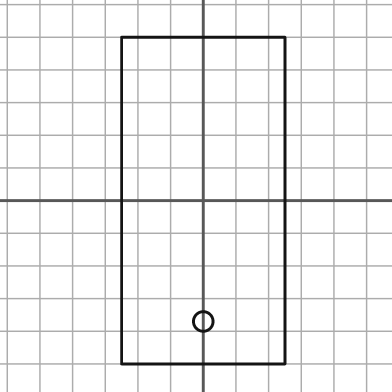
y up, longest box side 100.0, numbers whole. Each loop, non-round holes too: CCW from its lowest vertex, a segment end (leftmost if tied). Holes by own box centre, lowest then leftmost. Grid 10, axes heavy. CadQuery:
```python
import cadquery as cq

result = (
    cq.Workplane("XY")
    .moveTo(-25.0, -50.0)
    .lineTo(25.0, -50.0)
    .lineTo(25.0, 50.0)
    .lineTo(-25.0, 50.0)
    .close()
    .moveTo(0.0, -37.0)
    .circle(3.0)
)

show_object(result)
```